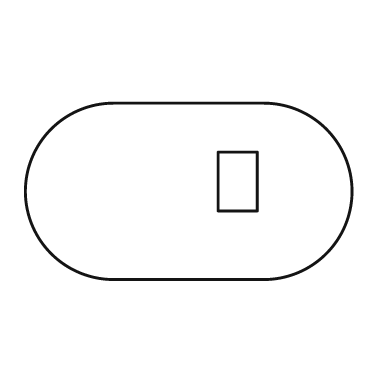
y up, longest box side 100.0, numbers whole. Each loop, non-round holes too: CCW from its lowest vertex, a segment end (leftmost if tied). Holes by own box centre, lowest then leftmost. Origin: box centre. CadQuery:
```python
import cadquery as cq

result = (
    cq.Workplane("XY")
    .moveTo(-23.0, -27.0)
    .lineTo(23.0, -27.0)
    .threePointArc((50.0, 0.0), (23.0, 27.0))
    .lineTo(-23.0, 27.0)
    .threePointArc((-50.0, 0.0), (-23.0, -27.0))
    .close()
    .moveTo(9.0, -6.0)
    .lineTo(21.0, -6.0)
    .lineTo(21.0, 12.0)
    .lineTo(9.0, 12.0)
    .close()
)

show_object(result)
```